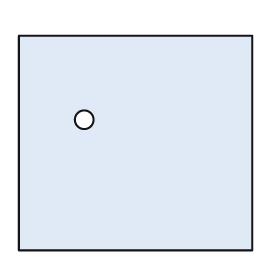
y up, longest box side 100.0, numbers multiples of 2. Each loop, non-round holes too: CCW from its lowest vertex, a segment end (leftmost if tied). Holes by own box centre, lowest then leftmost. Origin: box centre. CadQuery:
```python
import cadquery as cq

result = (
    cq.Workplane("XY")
    .moveTo(-50.0, -46.0)
    .lineTo(50.0, -46.0)
    .lineTo(50.0, 46.0)
    .lineTo(-50.0, 46.0)
    .close()
    .moveTo(-22.0, 10.0)
    .circle(4.0)
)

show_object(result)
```